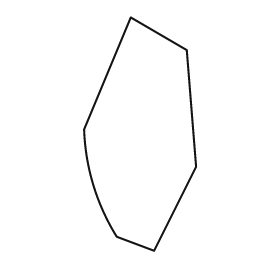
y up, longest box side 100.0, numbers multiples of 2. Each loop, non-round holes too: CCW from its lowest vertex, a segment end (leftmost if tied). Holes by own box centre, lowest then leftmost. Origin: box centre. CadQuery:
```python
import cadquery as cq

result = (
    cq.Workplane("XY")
    .moveTo(6.0, -50.0)
    .lineTo(24.0, -14.0)
    .lineTo(20.0, 36.0)
    .lineTo(-4.0, 50.0)
    .lineTo(-24.0, 2.0)
    .threePointArc((-20.0, -22.0), (-10.0, -44.0))
    .close()
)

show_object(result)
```